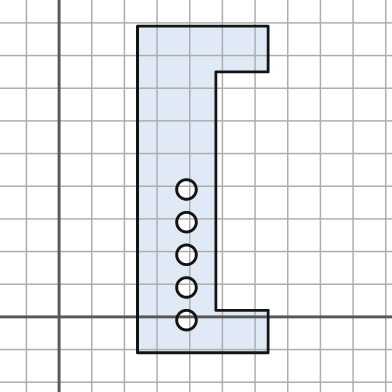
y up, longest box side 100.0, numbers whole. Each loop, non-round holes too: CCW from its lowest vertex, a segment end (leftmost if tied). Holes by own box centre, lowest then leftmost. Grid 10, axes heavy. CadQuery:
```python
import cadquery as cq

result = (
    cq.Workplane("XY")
    .moveTo(24.0, -11.0)
    .lineTo(64.0, -11.0)
    .lineTo(64.0, 2.0)
    .lineTo(48.0, 2.0)
    .lineTo(48.0, 75.0)
    .lineTo(64.0, 75.0)
    .lineTo(64.0, 89.0)
    .lineTo(24.0, 89.0)
    .close()
    .moveTo(39.0, -1.0)
    .circle(3.0)
    .moveTo(39.0, 9.0)
    .circle(3.0)
    .moveTo(39.0, 19.0)
    .circle(3.0)
    .moveTo(39.0, 29.0)
    .circle(3.0)
    .moveTo(39.0, 39.0)
    .circle(3.0)
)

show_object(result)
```